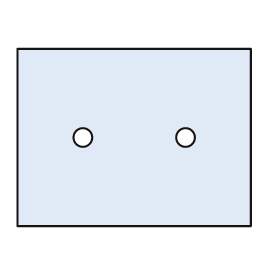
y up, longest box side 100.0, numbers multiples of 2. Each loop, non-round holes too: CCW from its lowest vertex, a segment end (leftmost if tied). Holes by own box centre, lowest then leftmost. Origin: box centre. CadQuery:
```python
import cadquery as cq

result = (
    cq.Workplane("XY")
    .moveTo(-50.0, -38.0)
    .lineTo(50.0, -38.0)
    .lineTo(50.0, 38.0)
    .lineTo(-50.0, 38.0)
    .close()
    .moveTo(-22.0, 0.0)
    .circle(4.0)
    .moveTo(22.0, 0.0)
    .circle(4.0)
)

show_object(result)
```